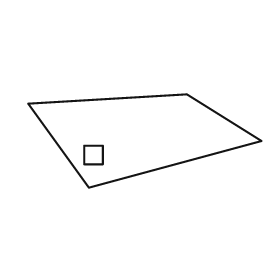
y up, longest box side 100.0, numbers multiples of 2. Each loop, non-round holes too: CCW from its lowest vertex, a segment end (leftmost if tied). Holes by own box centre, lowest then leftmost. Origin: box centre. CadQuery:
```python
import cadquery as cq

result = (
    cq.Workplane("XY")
    .moveTo(-24.0, -20.0)
    .lineTo(50.0, 0.0)
    .lineTo(18.0, 20.0)
    .lineTo(-50.0, 16.0)
    .close()
    .moveTo(-26.0, -10.0)
    .lineTo(-18.0, -10.0)
    .lineTo(-18.0, -2.0)
    .lineTo(-26.0, -2.0)
    .close()
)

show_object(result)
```